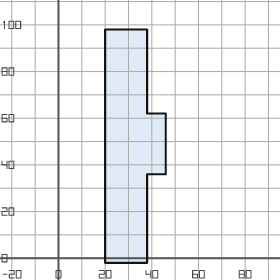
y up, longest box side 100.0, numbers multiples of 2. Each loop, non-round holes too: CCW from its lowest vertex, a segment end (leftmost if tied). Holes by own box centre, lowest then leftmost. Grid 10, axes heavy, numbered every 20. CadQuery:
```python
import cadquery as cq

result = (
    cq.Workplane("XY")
    .moveTo(20.0, -2.0)
    .lineTo(38.0, -2.0)
    .lineTo(38.0, 36.0)
    .lineTo(46.0, 36.0)
    .lineTo(46.0, 62.0)
    .lineTo(38.0, 62.0)
    .lineTo(38.0, 98.0)
    .lineTo(20.0, 98.0)
    .close()
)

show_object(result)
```